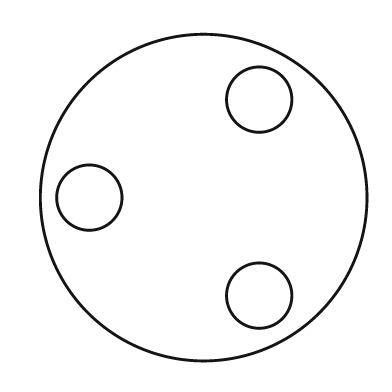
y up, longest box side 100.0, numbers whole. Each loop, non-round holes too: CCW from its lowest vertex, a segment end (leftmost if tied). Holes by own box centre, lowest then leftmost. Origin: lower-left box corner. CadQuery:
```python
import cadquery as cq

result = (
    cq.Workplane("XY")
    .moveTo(50.0, 50.0)
    .circle(50.0)
    .moveTo(67.0, 20.0)
    .circle(10.0)
    .moveTo(15.0, 50.0)
    .circle(10.0)
    .moveTo(67.0, 80.0)
    .circle(10.0)
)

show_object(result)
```